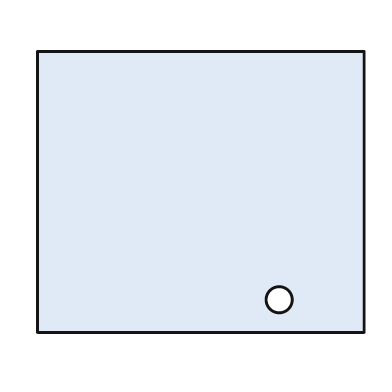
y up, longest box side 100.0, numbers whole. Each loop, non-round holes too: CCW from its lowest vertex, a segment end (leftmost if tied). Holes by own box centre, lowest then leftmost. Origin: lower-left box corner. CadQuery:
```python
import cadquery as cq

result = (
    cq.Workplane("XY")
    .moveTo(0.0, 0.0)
    .lineTo(100.0, 0.0)
    .lineTo(100.0, 86.0)
    .lineTo(0.0, 86.0)
    .close()
    .moveTo(74.0, 10.0)
    .circle(4.0)
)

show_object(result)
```